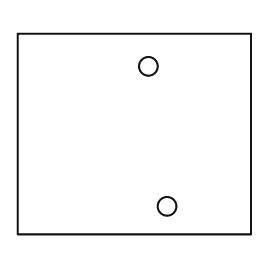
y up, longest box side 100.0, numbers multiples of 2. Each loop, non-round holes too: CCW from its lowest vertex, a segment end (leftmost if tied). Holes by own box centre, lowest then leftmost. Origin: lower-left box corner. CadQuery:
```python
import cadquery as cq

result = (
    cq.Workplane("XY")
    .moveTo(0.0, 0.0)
    .lineTo(100.0, 0.0)
    .lineTo(100.0, 86.0)
    .lineTo(0.0, 86.0)
    .close()
    .moveTo(64.0, 12.0)
    .circle(4.0)
    .moveTo(56.0, 72.0)
    .circle(4.0)
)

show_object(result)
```